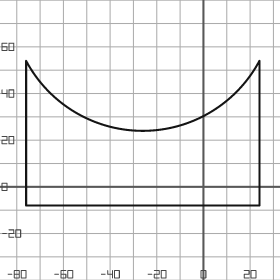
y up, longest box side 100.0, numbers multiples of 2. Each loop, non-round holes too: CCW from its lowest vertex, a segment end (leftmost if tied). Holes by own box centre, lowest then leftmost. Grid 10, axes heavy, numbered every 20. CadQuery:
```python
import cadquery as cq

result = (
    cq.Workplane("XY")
    .moveTo(-76.0, -8.0)
    .lineTo(24.0, -8.0)
    .lineTo(24.0, 54.0)
    .threePointArc((-26.0, 24.0), (-76.0, 54.0))
    .close()
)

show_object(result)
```